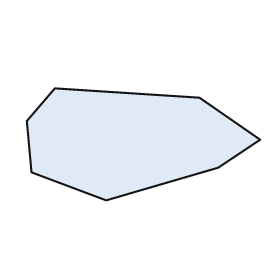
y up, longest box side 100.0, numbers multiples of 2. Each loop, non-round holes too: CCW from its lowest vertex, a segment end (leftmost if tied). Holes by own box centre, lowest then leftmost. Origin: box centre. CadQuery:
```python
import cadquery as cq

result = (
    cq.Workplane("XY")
    .moveTo(-16.0, -24.0)
    .lineTo(32.0, -10.0)
    .lineTo(50.0, 2.0)
    .lineTo(24.0, 20.0)
    .lineTo(-38.0, 24.0)
    .lineTo(-50.0, 10.0)
    .lineTo(-48.0, -12.0)
    .close()
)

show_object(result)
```